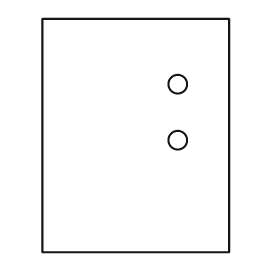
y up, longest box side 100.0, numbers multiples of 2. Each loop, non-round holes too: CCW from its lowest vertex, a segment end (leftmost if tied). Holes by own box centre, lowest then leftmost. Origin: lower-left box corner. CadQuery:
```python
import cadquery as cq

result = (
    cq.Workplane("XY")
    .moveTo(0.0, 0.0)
    .lineTo(80.0, 0.0)
    .lineTo(80.0, 100.0)
    .lineTo(0.0, 100.0)
    .close()
    .moveTo(58.0, 48.0)
    .circle(4.0)
    .moveTo(58.0, 72.0)
    .circle(4.0)
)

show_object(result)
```